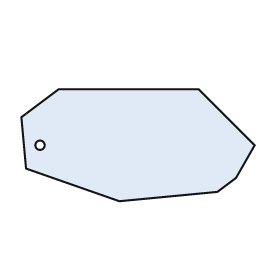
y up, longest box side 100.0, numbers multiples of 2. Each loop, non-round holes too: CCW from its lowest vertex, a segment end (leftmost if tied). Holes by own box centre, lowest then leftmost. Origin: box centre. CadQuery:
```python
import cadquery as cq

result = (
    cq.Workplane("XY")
    .moveTo(-8.0, -24.0)
    .lineTo(34.0, -20.0)
    .lineTo(42.0, -14.0)
    .lineTo(50.0, 0.0)
    .lineTo(26.0, 24.0)
    .lineTo(-34.0, 24.0)
    .lineTo(-50.0, 12.0)
    .lineTo(-48.0, -10.0)
    .close()
    .moveTo(-42.0, 0.0)
    .circle(2.0)
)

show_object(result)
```